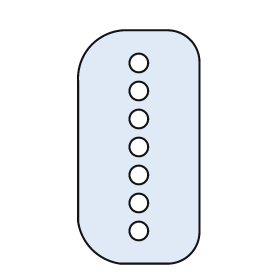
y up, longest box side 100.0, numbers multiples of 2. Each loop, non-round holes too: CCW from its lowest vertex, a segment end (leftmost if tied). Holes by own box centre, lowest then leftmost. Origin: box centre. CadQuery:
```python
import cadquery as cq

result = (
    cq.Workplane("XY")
    .moveTo(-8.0, -50.0)
    .lineTo(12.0, -50.0)
    .threePointArc((22.0, -46.0), (26.0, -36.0))
    .lineTo(26.0, 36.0)
    .threePointArc((22.0, 46.0), (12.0, 50.0))
    .lineTo(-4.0, 50.0)
    .threePointArc((-20.0, 44.0), (-26.0, 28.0))
    .lineTo(-26.0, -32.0)
    .threePointArc((-20.0, -44.0), (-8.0, -50.0))
    .close()
    .moveTo(0.0, -36.0)
    .circle(4.0)
    .moveTo(0.0, -24.0)
    .circle(4.0)
    .moveTo(0.0, -12.0)
    .circle(4.0)
    .moveTo(0.0, 0.0)
    .circle(4.0)
    .moveTo(0.0, 12.0)
    .circle(4.0)
    .moveTo(0.0, 24.0)
    .circle(4.0)
    .moveTo(0.0, 36.0)
    .circle(4.0)
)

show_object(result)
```